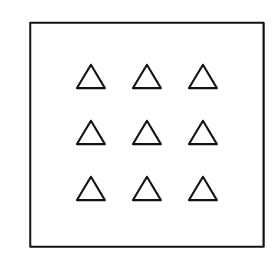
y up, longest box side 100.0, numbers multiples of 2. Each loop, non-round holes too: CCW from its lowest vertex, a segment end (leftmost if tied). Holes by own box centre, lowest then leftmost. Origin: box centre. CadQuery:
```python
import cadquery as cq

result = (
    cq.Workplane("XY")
    .moveTo(-50.0, -48.0)
    .lineTo(50.0, -48.0)
    .lineTo(50.0, 48.0)
    .lineTo(-50.0, 48.0)
    .close()
    .moveTo(-30.0, -28.0)
    .lineTo(-18.0, -28.0)
    .lineTo(-24.0, -18.0)
    .close()
    .moveTo(-6.0, -28.0)
    .lineTo(6.0, -28.0)
    .lineTo(0.0, -18.0)
    .close()
    .moveTo(18.0, -28.0)
    .lineTo(30.0, -28.0)
    .lineTo(24.0, -18.0)
    .close()
    .moveTo(-30.0, -4.0)
    .lineTo(-18.0, -4.0)
    .lineTo(-24.0, 6.0)
    .close()
    .moveTo(-6.0, -4.0)
    .lineTo(6.0, -4.0)
    .lineTo(0.0, 6.0)
    .close()
    .moveTo(18.0, -4.0)
    .lineTo(30.0, -4.0)
    .lineTo(24.0, 6.0)
    .close()
    .moveTo(-30.0, 20.0)
    .lineTo(-18.0, 20.0)
    .lineTo(-24.0, 30.0)
    .close()
    .moveTo(-6.0, 20.0)
    .lineTo(6.0, 20.0)
    .lineTo(0.0, 30.0)
    .close()
    .moveTo(18.0, 20.0)
    .lineTo(30.0, 20.0)
    .lineTo(24.0, 30.0)
    .close()
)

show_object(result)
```